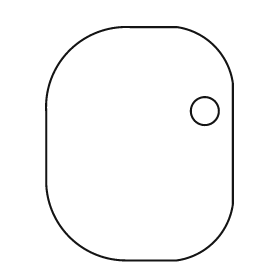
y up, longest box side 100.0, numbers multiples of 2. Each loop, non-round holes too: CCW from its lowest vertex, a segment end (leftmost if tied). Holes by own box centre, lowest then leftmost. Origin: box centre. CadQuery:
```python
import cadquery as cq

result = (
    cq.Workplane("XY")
    .moveTo(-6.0, -50.0)
    .lineTo(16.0, -50.0)
    .threePointArc((32.0, -42.0), (40.0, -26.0))
    .lineTo(40.0, 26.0)
    .threePointArc((32.0, 42.0), (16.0, 50.0))
    .lineTo(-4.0, 50.0)
    .threePointArc((-30.0, 40.0), (-40.0, 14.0))
    .lineTo(-40.0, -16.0)
    .threePointArc((-30.0, -40.0), (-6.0, -50.0))
    .close()
    .moveTo(28.0, 14.0)
    .circle(6.0)
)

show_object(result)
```